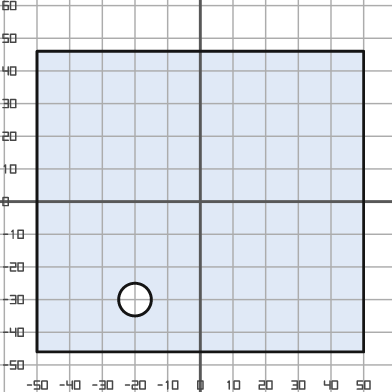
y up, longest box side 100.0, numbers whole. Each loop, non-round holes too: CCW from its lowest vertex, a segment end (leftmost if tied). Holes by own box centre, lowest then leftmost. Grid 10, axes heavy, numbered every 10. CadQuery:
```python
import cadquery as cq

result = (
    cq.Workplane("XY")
    .moveTo(-50.0, -46.0)
    .lineTo(50.0, -46.0)
    .lineTo(50.0, 46.0)
    .lineTo(-50.0, 46.0)
    .close()
    .moveTo(-20.0, -30.0)
    .circle(5.0)
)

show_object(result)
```